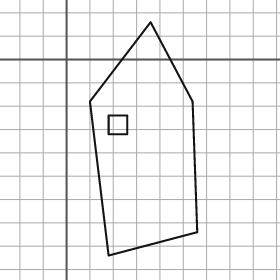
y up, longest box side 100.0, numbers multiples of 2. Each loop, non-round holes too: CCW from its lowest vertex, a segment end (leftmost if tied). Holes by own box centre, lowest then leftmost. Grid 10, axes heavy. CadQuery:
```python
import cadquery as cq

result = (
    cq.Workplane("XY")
    .moveTo(18.0, -84.0)
    .lineTo(56.0, -74.0)
    .lineTo(54.0, -18.0)
    .lineTo(36.0, 16.0)
    .lineTo(10.0, -18.0)
    .close()
    .moveTo(18.0, -32.0)
    .lineTo(26.0, -32.0)
    .lineTo(26.0, -24.0)
    .lineTo(18.0, -24.0)
    .close()
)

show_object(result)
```